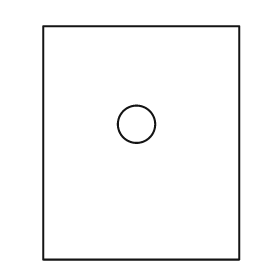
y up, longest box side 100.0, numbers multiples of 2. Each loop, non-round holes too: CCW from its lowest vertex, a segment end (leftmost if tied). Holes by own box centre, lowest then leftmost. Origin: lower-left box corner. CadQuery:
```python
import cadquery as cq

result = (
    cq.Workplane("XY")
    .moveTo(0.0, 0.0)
    .lineTo(84.0, 0.0)
    .lineTo(84.0, 100.0)
    .lineTo(0.0, 100.0)
    .close()
    .moveTo(40.0, 58.0)
    .circle(8.0)
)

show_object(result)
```